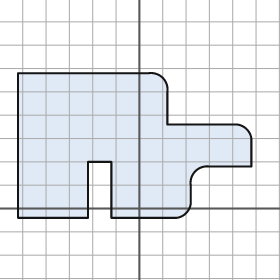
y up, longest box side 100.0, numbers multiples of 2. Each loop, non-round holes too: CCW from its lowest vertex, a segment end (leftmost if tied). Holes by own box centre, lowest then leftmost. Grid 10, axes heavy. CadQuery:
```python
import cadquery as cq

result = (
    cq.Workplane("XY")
    .moveTo(-52.0, -4.0)
    .lineTo(-22.0, -4.0)
    .lineTo(-22.0, 20.0)
    .lineTo(-12.0, 20.0)
    .lineTo(-12.0, -4.0)
    .lineTo(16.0, -4.0)
    .threePointArc((20.0, -2.0), (22.0, 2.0))
    .lineTo(22.0, 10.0)
    .threePointArc((24.0, 16.0), (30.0, 18.0))
    .lineTo(48.0, 18.0)
    .lineTo(48.0, 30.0)
    .threePointArc((46.0, 34.0), (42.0, 36.0))
    .lineTo(12.0, 36.0)
    .lineTo(12.0, 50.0)
    .threePointArc((10.0, 56.0), (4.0, 58.0))
    .lineTo(-52.0, 58.0)
    .close()
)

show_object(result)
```